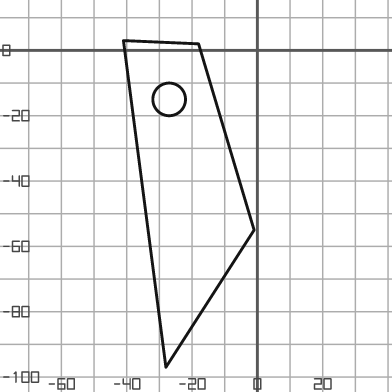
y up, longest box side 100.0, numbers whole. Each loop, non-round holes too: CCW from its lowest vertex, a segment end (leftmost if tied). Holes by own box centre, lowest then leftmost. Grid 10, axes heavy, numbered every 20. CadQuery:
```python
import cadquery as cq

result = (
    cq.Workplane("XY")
    .moveTo(-28.0, -97.0)
    .lineTo(-1.0, -55.0)
    .lineTo(-18.0, 2.0)
    .lineTo(-41.0, 3.0)
    .close()
    .moveTo(-27.0, -15.0)
    .circle(5.0)
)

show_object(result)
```